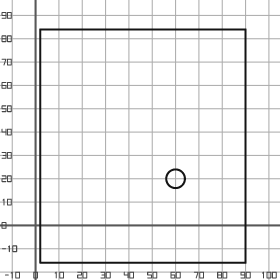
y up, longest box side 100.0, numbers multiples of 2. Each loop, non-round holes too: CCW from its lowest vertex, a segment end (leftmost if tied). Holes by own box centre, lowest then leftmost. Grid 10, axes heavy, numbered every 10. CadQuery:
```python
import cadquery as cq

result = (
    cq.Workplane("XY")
    .moveTo(2.0, -16.0)
    .lineTo(90.0, -16.0)
    .lineTo(90.0, 84.0)
    .lineTo(2.0, 84.0)
    .close()
    .moveTo(60.0, 20.0)
    .circle(4.0)
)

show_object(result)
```